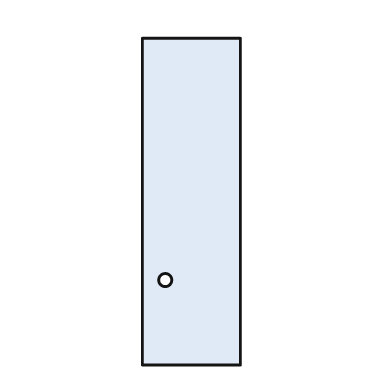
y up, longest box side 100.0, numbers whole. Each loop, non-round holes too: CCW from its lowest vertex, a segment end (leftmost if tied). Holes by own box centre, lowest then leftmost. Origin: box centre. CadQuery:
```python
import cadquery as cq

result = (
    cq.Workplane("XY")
    .moveTo(-15.0, -50.0)
    .lineTo(15.0, -50.0)
    .lineTo(15.0, 50.0)
    .lineTo(-15.0, 50.0)
    .close()
    .moveTo(-8.0, -24.0)
    .circle(2.0)
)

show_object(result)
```